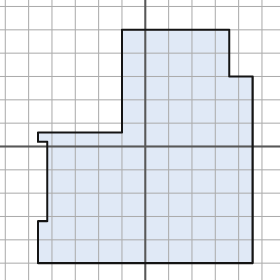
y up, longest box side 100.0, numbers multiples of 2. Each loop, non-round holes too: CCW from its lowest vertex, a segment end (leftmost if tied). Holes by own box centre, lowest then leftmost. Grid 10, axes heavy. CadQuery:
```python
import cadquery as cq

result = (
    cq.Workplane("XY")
    .moveTo(-46.0, -50.0)
    .lineTo(46.0, -50.0)
    .lineTo(46.0, 30.0)
    .lineTo(36.0, 30.0)
    .lineTo(36.0, 50.0)
    .lineTo(-10.0, 50.0)
    .lineTo(-10.0, 6.0)
    .lineTo(-46.0, 6.0)
    .lineTo(-46.0, 2.0)
    .lineTo(-42.0, 2.0)
    .lineTo(-42.0, -32.0)
    .lineTo(-46.0, -32.0)
    .close()
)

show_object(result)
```